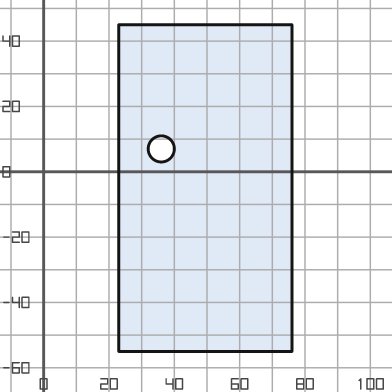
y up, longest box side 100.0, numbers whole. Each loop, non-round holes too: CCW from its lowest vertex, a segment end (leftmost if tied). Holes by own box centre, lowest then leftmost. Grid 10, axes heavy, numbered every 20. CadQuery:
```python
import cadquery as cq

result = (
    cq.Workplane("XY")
    .moveTo(23.0, -55.0)
    .lineTo(76.0, -55.0)
    .lineTo(76.0, 45.0)
    .lineTo(23.0, 45.0)
    .close()
    .moveTo(36.0, 7.0)
    .circle(4.0)
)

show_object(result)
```